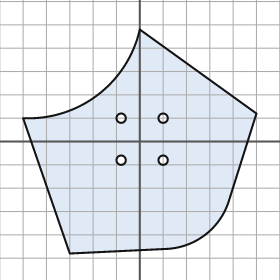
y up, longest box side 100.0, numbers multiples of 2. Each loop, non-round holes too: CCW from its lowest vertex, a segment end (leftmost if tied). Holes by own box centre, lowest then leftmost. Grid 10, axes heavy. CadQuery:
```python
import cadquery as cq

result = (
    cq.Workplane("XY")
    .moveTo(-30.0, -48.0)
    .lineTo(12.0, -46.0)
    .threePointArc((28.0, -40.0), (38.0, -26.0))
    .lineTo(50.0, 12.0)
    .lineTo(0.0, 48.0)
    .threePointArc((-18.0, 20.0), (-50.0, 10.0))
    .close()
    .moveTo(-8.0, -8.0)
    .circle(2.0)
    .moveTo(10.0, -8.0)
    .circle(2.0)
    .moveTo(-8.0, 10.0)
    .circle(2.0)
    .moveTo(10.0, 10.0)
    .circle(2.0)
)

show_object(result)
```